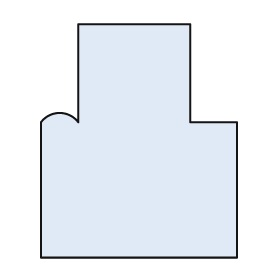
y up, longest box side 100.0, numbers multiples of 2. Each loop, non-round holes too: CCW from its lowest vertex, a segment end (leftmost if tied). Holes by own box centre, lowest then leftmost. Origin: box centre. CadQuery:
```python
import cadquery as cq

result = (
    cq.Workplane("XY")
    .moveTo(-42.0, -50.0)
    .lineTo(42.0, -50.0)
    .lineTo(42.0, 8.0)
    .lineTo(22.0, 8.0)
    .lineTo(22.0, 50.0)
    .lineTo(-26.0, 50.0)
    .lineTo(-26.0, 8.0)
    .threePointArc((-34.0, 12.0), (-42.0, 8.0))
    .close()
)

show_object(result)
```